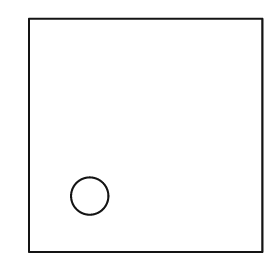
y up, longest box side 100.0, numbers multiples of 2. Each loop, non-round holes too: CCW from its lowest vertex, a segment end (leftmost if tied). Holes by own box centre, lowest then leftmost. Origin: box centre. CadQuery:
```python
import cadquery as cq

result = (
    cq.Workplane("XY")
    .moveTo(-50.0, -50.0)
    .lineTo(50.0, -50.0)
    .lineTo(50.0, 50.0)
    .lineTo(-50.0, 50.0)
    .close()
    .moveTo(-24.0, -26.0)
    .circle(8.0)
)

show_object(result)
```